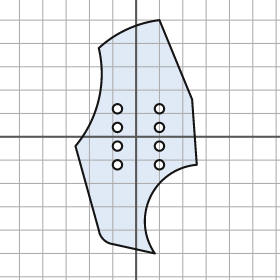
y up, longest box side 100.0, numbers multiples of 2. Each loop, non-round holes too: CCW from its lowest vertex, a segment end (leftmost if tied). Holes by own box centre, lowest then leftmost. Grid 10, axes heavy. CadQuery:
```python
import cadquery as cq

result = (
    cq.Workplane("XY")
    .moveTo(8.0, -50.0)
    .threePointArc((6.0, -26.0), (26.0, -12.0))
    .lineTo(24.0, 16.0)
    .lineTo(10.0, 50.0)
    .threePointArc((-4.0, 46.0), (-16.0, 38.0))
    .threePointArc((-16.0, 16.0), (-26.0, -4.0))
    .lineTo(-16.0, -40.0)
    .threePointArc((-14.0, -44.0), (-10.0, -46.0))
    .close()
    .moveTo(-8.0, -12.0)
    .circle(2.0)
    .moveTo(10.0, -12.0)
    .circle(2.0)
    .moveTo(-8.0, -4.0)
    .circle(2.0)
    .moveTo(10.0, -4.0)
    .circle(2.0)
    .moveTo(-8.0, 4.0)
    .circle(2.0)
    .moveTo(10.0, 4.0)
    .circle(2.0)
    .moveTo(-8.0, 12.0)
    .circle(2.0)
    .moveTo(10.0, 12.0)
    .circle(2.0)
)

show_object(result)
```